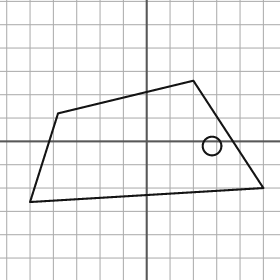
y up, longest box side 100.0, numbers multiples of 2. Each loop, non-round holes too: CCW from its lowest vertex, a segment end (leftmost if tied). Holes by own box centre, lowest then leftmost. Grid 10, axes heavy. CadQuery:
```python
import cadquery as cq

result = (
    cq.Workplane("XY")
    .moveTo(-50.0, -26.0)
    .lineTo(50.0, -20.0)
    .lineTo(20.0, 26.0)
    .lineTo(-38.0, 12.0)
    .close()
    .moveTo(28.0, -2.0)
    .circle(4.0)
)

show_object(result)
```